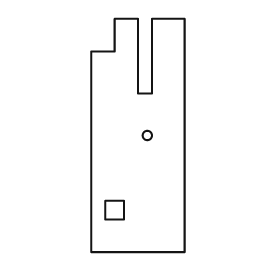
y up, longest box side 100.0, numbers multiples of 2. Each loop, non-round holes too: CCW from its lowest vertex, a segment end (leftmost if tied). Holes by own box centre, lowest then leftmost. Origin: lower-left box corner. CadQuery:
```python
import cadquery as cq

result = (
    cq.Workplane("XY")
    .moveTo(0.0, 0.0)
    .lineTo(40.0, 0.0)
    .lineTo(40.0, 100.0)
    .lineTo(26.0, 100.0)
    .lineTo(26.0, 68.0)
    .lineTo(20.0, 68.0)
    .lineTo(20.0, 100.0)
    .lineTo(10.0, 100.0)
    .lineTo(10.0, 86.0)
    .lineTo(0.0, 86.0)
    .close()
    .moveTo(6.0, 14.0)
    .lineTo(14.0, 14.0)
    .lineTo(14.0, 22.0)
    .lineTo(6.0, 22.0)
    .close()
    .moveTo(24.0, 50.0)
    .circle(2.0)
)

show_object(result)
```